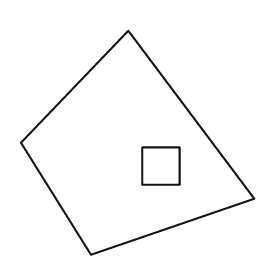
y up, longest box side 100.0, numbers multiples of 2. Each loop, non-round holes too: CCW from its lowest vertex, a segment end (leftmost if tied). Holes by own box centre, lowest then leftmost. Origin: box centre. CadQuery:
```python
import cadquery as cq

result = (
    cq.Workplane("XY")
    .moveTo(-20.0, -48.0)
    .lineTo(50.0, -24.0)
    .lineTo(-4.0, 48.0)
    .lineTo(-50.0, 0.0)
    .close()
    .moveTo(2.0, -18.0)
    .lineTo(18.0, -18.0)
    .lineTo(18.0, -2.0)
    .lineTo(2.0, -2.0)
    .close()
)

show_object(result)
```